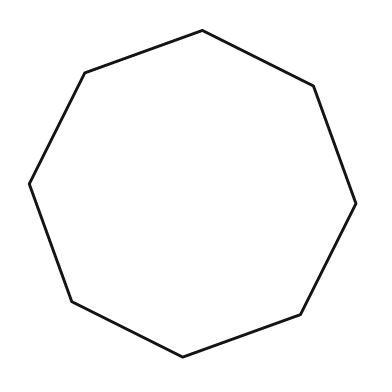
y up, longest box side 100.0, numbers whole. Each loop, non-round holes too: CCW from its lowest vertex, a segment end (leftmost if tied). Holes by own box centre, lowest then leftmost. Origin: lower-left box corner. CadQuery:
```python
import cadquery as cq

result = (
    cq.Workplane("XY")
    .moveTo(47.0, 0.0)
    .lineTo(83.0, 13.0)
    .lineTo(100.0, 47.0)
    .lineTo(87.0, 83.0)
    .lineTo(53.0, 100.0)
    .lineTo(17.0, 87.0)
    .lineTo(0.0, 53.0)
    .lineTo(13.0, 17.0)
    .close()
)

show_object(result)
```